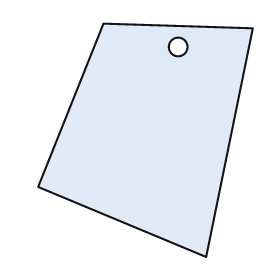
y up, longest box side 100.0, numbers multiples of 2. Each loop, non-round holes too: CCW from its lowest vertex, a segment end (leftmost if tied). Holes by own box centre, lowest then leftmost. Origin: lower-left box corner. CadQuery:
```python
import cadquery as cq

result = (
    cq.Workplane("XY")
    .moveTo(72.0, 0.0)
    .lineTo(92.0, 98.0)
    .lineTo(28.0, 100.0)
    .lineTo(0.0, 30.0)
    .close()
    .moveTo(60.0, 90.0)
    .circle(4.0)
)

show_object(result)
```